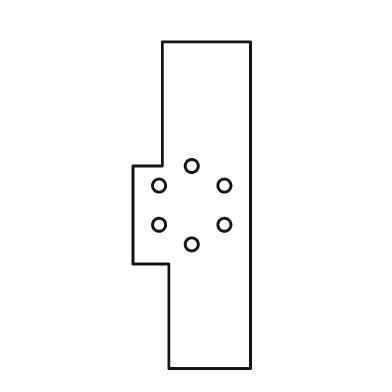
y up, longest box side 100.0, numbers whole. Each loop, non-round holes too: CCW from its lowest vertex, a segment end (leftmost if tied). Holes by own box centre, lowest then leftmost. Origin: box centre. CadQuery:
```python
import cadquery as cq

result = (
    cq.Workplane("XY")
    .moveTo(-7.0, -50.0)
    .lineTo(18.0, -50.0)
    .lineTo(18.0, 50.0)
    .lineTo(-9.0, 50.0)
    .lineTo(-9.0, 12.0)
    .lineTo(-18.0, 12.0)
    .lineTo(-18.0, -18.0)
    .lineTo(-7.0, -18.0)
    .close()
    .moveTo(0.0, -12.0)
    .circle(2.0)
    .moveTo(-10.0, -6.0)
    .circle(2.0)
    .moveTo(10.0, -6.0)
    .circle(2.0)
    .moveTo(-10.0, 6.0)
    .circle(2.0)
    .moveTo(10.0, 6.0)
    .circle(2.0)
    .moveTo(0.0, 12.0)
    .circle(2.0)
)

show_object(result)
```